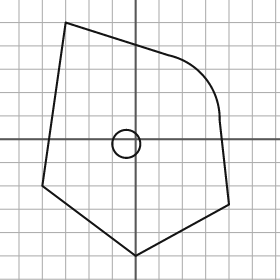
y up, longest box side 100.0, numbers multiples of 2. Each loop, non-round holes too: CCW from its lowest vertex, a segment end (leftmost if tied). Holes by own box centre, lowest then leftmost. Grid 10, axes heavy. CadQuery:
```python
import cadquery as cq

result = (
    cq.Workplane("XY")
    .moveTo(0.0, -50.0)
    .lineTo(40.0, -28.0)
    .lineTo(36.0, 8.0)
    .threePointArc((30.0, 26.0), (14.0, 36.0))
    .lineTo(-30.0, 50.0)
    .lineTo(-40.0, -20.0)
    .close()
    .moveTo(-4.0, -2.0)
    .circle(6.0)
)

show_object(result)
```